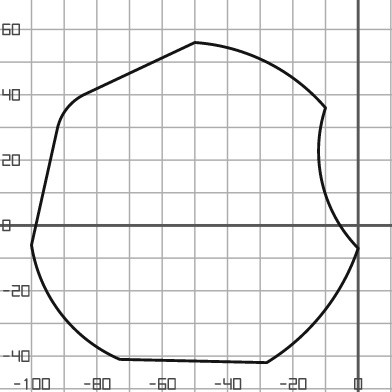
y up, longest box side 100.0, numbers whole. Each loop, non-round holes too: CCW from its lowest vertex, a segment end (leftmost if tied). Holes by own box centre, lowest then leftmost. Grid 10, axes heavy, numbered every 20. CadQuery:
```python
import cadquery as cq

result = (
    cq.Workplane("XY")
    .moveTo(-28.0, -42.0)
    .threePointArc((-11.0, -27.0), (0.0, -7.0))
    .threePointArc((-11.0, 13.0), (-10.0, 36.0))
    .threePointArc((-28.0, 50.0), (-50.0, 56.0))
    .lineTo(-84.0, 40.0)
    .threePointArc((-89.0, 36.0), (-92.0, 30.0))
    .lineTo(-100.0, -6.0)
    .threePointArc((-91.0, -27.0), (-73.0, -41.0))
    .close()
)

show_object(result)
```